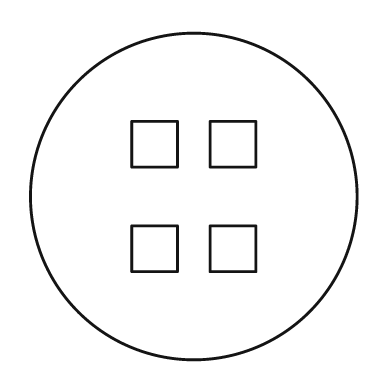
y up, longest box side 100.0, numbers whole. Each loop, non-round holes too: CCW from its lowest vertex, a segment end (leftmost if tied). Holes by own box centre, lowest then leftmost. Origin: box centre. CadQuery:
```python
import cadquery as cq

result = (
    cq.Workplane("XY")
    .moveTo(0.0, 0.0)
    .circle(50.0)
    .moveTo(-19.0, -23.0)
    .lineTo(-5.0, -23.0)
    .lineTo(-5.0, -9.0)
    .lineTo(-19.0, -9.0)
    .close()
    .moveTo(5.0, -23.0)
    .lineTo(19.0, -23.0)
    .lineTo(19.0, -9.0)
    .lineTo(5.0, -9.0)
    .close()
    .moveTo(-19.0, 9.0)
    .lineTo(-5.0, 9.0)
    .lineTo(-5.0, 23.0)
    .lineTo(-19.0, 23.0)
    .close()
    .moveTo(5.0, 9.0)
    .lineTo(19.0, 9.0)
    .lineTo(19.0, 23.0)
    .lineTo(5.0, 23.0)
    .close()
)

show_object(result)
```